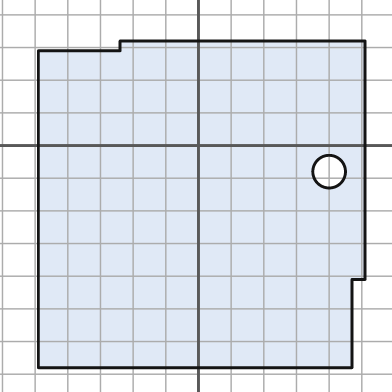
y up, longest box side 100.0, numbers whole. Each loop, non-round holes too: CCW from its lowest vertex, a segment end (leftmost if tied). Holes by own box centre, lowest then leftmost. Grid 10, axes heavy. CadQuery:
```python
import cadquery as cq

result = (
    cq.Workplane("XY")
    .moveTo(-49.0, -68.0)
    .lineTo(47.0, -68.0)
    .lineTo(47.0, -41.0)
    .lineTo(51.0, -41.0)
    .lineTo(51.0, 32.0)
    .lineTo(-24.0, 32.0)
    .lineTo(-24.0, 29.0)
    .lineTo(-49.0, 29.0)
    .close()
    .moveTo(40.0, -8.0)
    .circle(5.0)
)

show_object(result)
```